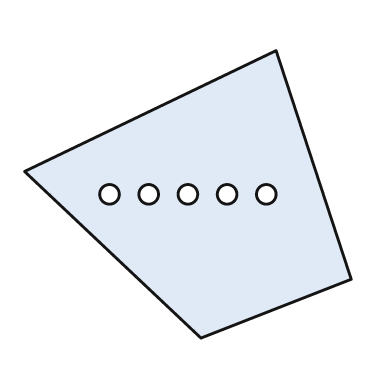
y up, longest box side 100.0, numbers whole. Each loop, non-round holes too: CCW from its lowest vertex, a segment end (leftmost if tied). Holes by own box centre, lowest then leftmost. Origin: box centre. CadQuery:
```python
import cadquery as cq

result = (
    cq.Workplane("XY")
    .moveTo(4.0, -44.0)
    .lineTo(50.0, -26.0)
    .lineTo(27.0, 44.0)
    .lineTo(-50.0, 7.0)
    .close()
    .moveTo(-24.0, 0.0)
    .circle(3.0)
    .moveTo(-12.0, 0.0)
    .circle(3.0)
    .moveTo(0.0, 0.0)
    .circle(3.0)
    .moveTo(12.0, 0.0)
    .circle(3.0)
    .moveTo(24.0, 0.0)
    .circle(3.0)
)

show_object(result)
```